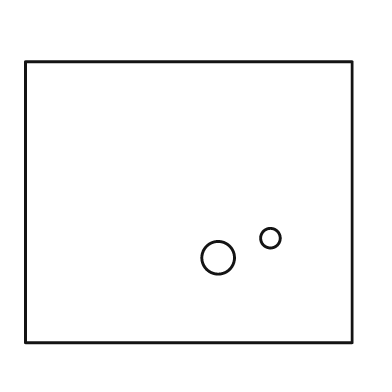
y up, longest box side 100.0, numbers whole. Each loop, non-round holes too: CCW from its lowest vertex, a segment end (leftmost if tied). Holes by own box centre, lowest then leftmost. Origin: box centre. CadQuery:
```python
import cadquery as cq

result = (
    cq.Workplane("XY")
    .moveTo(-50.0, -43.0)
    .lineTo(50.0, -43.0)
    .lineTo(50.0, 43.0)
    .lineTo(-50.0, 43.0)
    .close()
    .moveTo(9.0, -17.0)
    .circle(5.0)
    .moveTo(25.0, -11.0)
    .circle(3.0)
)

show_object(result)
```